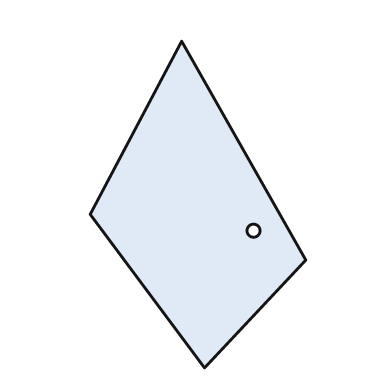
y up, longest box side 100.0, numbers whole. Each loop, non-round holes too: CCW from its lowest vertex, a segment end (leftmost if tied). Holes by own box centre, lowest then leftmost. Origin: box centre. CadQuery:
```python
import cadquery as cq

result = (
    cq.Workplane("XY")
    .moveTo(2.0, -50.0)
    .lineTo(33.0, -17.0)
    .lineTo(-5.0, 50.0)
    .lineTo(-33.0, -3.0)
    .close()
    .moveTo(17.0, -8.0)
    .circle(2.0)
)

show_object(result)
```